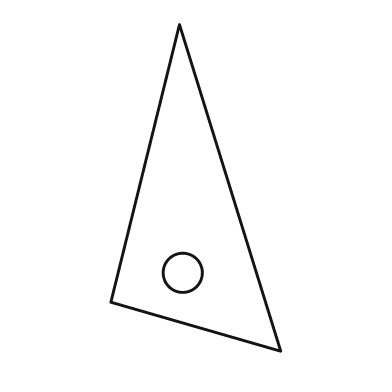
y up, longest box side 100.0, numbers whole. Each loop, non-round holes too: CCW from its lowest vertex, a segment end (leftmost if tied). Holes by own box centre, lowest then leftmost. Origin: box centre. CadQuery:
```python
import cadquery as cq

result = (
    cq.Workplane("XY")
    .moveTo(26.0, -50.0)
    .lineTo(-5.0, 50.0)
    .lineTo(-26.0, -35.0)
    .close()
    .moveTo(-4.0, -26.0)
    .circle(6.0)
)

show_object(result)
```